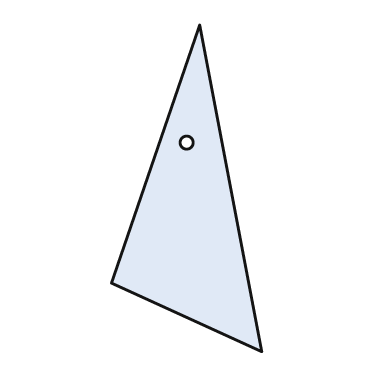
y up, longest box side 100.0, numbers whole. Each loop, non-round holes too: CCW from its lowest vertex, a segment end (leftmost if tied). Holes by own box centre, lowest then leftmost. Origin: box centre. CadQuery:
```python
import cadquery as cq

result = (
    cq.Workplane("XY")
    .moveTo(23.0, -50.0)
    .lineTo(4.0, 50.0)
    .lineTo(-23.0, -29.0)
    .close()
    .moveTo(0.0, 14.0)
    .circle(2.0)
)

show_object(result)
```